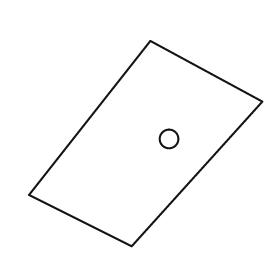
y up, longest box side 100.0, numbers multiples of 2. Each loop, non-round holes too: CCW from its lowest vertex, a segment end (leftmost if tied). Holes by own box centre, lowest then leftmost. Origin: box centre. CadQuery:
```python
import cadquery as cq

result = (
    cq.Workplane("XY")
    .moveTo(-6.0, -44.0)
    .lineTo(50.0, 18.0)
    .lineTo(2.0, 44.0)
    .lineTo(-50.0, -22.0)
    .close()
    .moveTo(10.0, 2.0)
    .circle(4.0)
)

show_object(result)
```